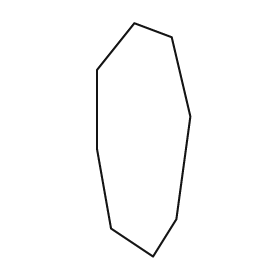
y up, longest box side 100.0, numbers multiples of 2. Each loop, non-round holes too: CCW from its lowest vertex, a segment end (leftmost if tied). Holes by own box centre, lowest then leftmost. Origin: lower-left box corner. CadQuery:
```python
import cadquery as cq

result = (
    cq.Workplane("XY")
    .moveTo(24.0, 0.0)
    .lineTo(34.0, 16.0)
    .lineTo(40.0, 60.0)
    .lineTo(32.0, 94.0)
    .lineTo(16.0, 100.0)
    .lineTo(0.0, 80.0)
    .lineTo(0.0, 46.0)
    .lineTo(6.0, 12.0)
    .close()
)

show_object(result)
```